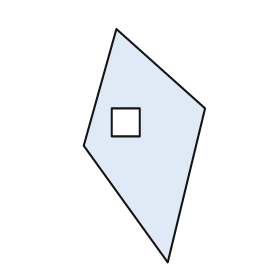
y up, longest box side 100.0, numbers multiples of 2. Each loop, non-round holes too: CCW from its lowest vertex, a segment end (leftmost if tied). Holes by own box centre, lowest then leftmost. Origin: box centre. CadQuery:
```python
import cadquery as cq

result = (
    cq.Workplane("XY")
    .moveTo(10.0, -50.0)
    .lineTo(26.0, 16.0)
    .lineTo(-12.0, 50.0)
    .lineTo(-26.0, 0.0)
    .close()
    .moveTo(-14.0, 4.0)
    .lineTo(-2.0, 4.0)
    .lineTo(-2.0, 16.0)
    .lineTo(-14.0, 16.0)
    .close()
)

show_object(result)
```